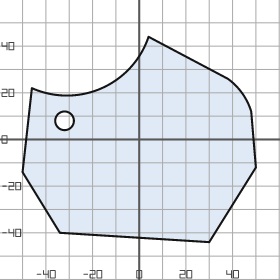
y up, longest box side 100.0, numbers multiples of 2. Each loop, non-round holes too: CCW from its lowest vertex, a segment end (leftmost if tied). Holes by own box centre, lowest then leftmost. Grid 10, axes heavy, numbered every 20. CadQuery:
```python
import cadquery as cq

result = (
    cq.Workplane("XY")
    .moveTo(30.0, -44.0)
    .lineTo(50.0, -12.0)
    .lineTo(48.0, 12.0)
    .threePointArc((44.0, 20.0), (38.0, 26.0))
    .lineTo(4.0, 44.0)
    .threePointArc((-16.0, 22.0), (-46.0, 22.0))
    .lineTo(-50.0, -14.0)
    .lineTo(-34.0, -40.0)
    .close()
    .moveTo(-32.0, 8.0)
    .circle(4.0)
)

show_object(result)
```